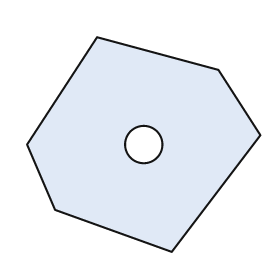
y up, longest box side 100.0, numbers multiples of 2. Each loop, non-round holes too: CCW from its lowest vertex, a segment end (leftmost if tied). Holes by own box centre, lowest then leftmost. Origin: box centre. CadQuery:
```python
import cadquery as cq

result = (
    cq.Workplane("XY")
    .moveTo(12.0, -46.0)
    .lineTo(50.0, 4.0)
    .lineTo(32.0, 32.0)
    .lineTo(-20.0, 46.0)
    .lineTo(-50.0, 0.0)
    .lineTo(-38.0, -28.0)
    .close()
    .moveTo(0.0, 0.0)
    .circle(8.0)
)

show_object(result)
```